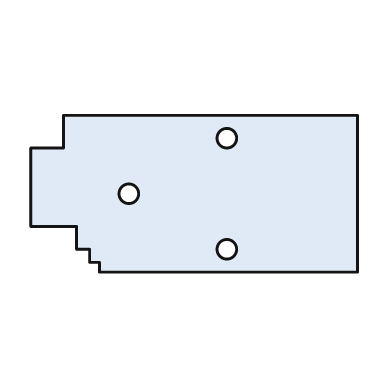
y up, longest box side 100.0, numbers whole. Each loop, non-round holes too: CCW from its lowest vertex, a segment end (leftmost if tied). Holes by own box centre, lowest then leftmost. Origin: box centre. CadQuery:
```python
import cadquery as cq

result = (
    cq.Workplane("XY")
    .moveTo(-29.0, -24.0)
    .lineTo(50.0, -24.0)
    .lineTo(50.0, 24.0)
    .lineTo(-40.0, 24.0)
    .lineTo(-40.0, 14.0)
    .lineTo(-50.0, 14.0)
    .lineTo(-50.0, -10.0)
    .lineTo(-36.0, -10.0)
    .lineTo(-36.0, -17.0)
    .lineTo(-32.0, -17.0)
    .lineTo(-32.0, -21.0)
    .lineTo(-29.0, -21.0)
    .close()
    .moveTo(10.0, -17.0)
    .circle(3.0)
    .moveTo(-20.0, 0.0)
    .circle(3.0)
    .moveTo(10.0, 17.0)
    .circle(3.0)
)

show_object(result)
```